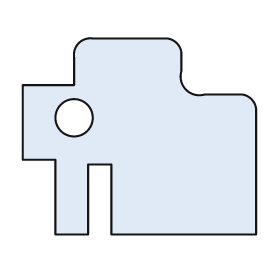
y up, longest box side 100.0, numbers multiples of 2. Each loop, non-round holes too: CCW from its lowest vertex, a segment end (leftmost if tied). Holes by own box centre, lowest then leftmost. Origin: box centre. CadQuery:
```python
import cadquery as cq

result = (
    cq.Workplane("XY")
    .moveTo(-36.0, -42.0)
    .lineTo(-22.0, -42.0)
    .lineTo(-22.0, -12.0)
    .lineTo(-12.0, -12.0)
    .lineTo(-12.0, -42.0)
    .lineTo(50.0, -42.0)
    .lineTo(50.0, 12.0)
    .threePointArc((48.0, 16.0), (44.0, 18.0))
    .lineTo(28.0, 18.0)
    .threePointArc((20.0, 20.0), (18.0, 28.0))
    .lineTo(18.0, 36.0)
    .threePointArc((16.0, 40.0), (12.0, 42.0))
    .lineTo(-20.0, 42.0)
    .threePointArc((-26.0, 40.0), (-28.0, 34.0))
    .lineTo(-28.0, 22.0)
    .lineTo(-50.0, 22.0)
    .lineTo(-50.0, -10.0)
    .lineTo(-36.0, -10.0)
    .close()
    .moveTo(-28.0, 8.0)
    .circle(8.0)
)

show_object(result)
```